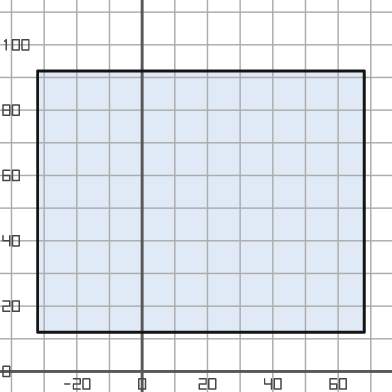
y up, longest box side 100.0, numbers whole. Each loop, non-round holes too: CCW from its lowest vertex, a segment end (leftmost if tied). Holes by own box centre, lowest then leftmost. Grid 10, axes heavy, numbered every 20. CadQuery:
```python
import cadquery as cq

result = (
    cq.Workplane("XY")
    .moveTo(-32.0, 12.0)
    .lineTo(68.0, 12.0)
    .lineTo(68.0, 92.0)
    .lineTo(-32.0, 92.0)
    .close()
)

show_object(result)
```